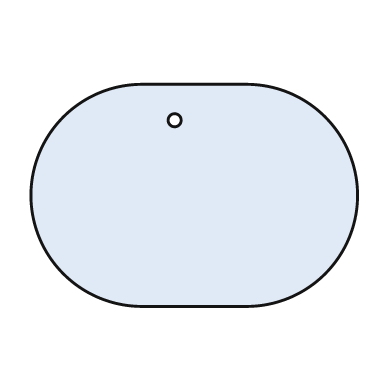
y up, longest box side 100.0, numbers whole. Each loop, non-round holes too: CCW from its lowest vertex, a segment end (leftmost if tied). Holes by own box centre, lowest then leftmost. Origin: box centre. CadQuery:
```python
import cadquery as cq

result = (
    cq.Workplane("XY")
    .moveTo(-16.0, -34.0)
    .lineTo(16.0, -34.0)
    .threePointArc((50.0, 0.0), (16.0, 34.0))
    .lineTo(-16.0, 34.0)
    .threePointArc((-50.0, 0.0), (-16.0, -34.0))
    .close()
    .moveTo(-6.0, 23.0)
    .circle(2.0)
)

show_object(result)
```